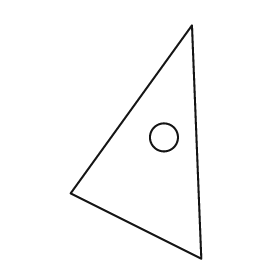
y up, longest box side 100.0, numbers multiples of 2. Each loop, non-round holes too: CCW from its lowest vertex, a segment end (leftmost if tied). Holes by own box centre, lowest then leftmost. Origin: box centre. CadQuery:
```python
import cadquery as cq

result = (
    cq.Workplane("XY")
    .moveTo(28.0, -50.0)
    .lineTo(24.0, 50.0)
    .lineTo(-28.0, -22.0)
    .close()
    .moveTo(12.0, 2.0)
    .circle(6.0)
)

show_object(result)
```